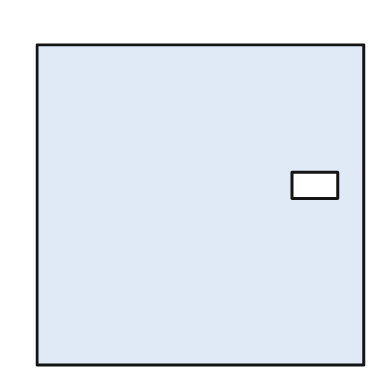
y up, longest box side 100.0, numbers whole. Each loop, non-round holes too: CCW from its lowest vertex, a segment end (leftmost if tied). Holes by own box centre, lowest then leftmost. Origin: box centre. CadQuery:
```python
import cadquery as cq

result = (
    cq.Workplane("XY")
    .moveTo(-50.0, -49.0)
    .lineTo(50.0, -49.0)
    .lineTo(50.0, 49.0)
    .lineTo(-50.0, 49.0)
    .close()
    .moveTo(28.0, 2.0)
    .lineTo(42.0, 2.0)
    .lineTo(42.0, 10.0)
    .lineTo(28.0, 10.0)
    .close()
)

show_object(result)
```